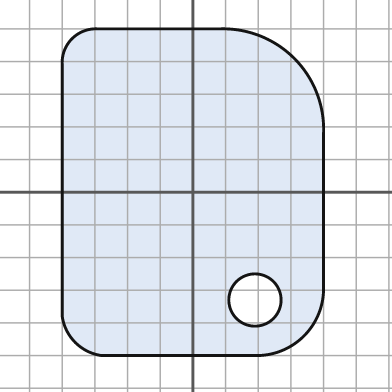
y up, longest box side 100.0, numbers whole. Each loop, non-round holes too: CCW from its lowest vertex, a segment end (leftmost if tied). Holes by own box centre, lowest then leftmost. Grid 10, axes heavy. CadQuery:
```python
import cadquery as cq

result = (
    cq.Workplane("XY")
    .moveTo(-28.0, -50.0)
    .lineTo(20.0, -50.0)
    .threePointArc((34.0, -44.0), (40.0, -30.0))
    .lineTo(40.0, 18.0)
    .threePointArc((31.0, 41.0), (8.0, 50.0))
    .lineTo(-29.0, 50.0)
    .threePointArc((-37.0, 47.0), (-40.0, 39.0))
    .lineTo(-40.0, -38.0)
    .threePointArc((-36.0, -46.0), (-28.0, -50.0))
    .close()
    .moveTo(19.0, -33.0)
    .circle(8.0)
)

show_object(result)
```